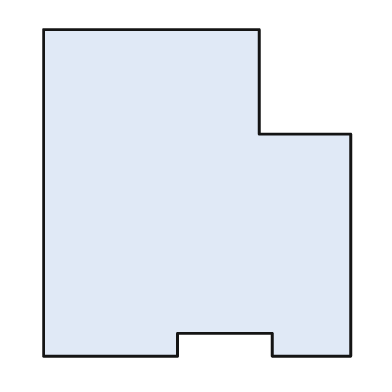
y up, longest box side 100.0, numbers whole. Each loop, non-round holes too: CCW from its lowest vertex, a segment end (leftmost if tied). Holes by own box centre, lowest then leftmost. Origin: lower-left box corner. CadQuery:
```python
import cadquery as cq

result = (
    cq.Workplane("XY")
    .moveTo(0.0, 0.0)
    .lineTo(41.0, 0.0)
    .lineTo(41.0, 7.0)
    .lineTo(70.0, 7.0)
    .lineTo(70.0, 0.0)
    .lineTo(94.0, 0.0)
    .lineTo(94.0, 68.0)
    .lineTo(66.0, 68.0)
    .lineTo(66.0, 100.0)
    .lineTo(0.0, 100.0)
    .close()
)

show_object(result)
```